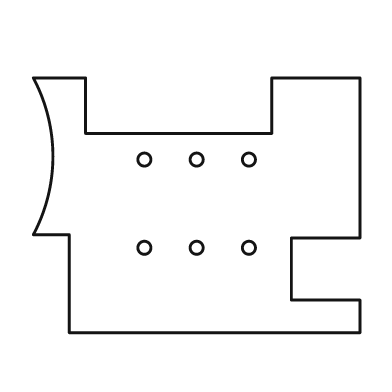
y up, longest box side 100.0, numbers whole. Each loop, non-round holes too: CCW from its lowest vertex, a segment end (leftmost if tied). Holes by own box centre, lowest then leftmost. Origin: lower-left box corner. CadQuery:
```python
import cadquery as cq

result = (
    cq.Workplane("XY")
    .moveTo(11.0, 0.0)
    .lineTo(100.0, 0.0)
    .lineTo(100.0, 10.0)
    .lineTo(79.0, 10.0)
    .lineTo(79.0, 29.0)
    .lineTo(100.0, 29.0)
    .lineTo(100.0, 78.0)
    .lineTo(73.0, 78.0)
    .lineTo(73.0, 61.0)
    .lineTo(16.0, 61.0)
    .lineTo(16.0, 78.0)
    .lineTo(0.0, 78.0)
    .threePointArc((6.0, 54.0), (0.0, 30.0))
    .lineTo(11.0, 30.0)
    .close()
    .moveTo(34.0, 26.0)
    .circle(2.0)
    .moveTo(50.0, 26.0)
    .circle(2.0)
    .moveTo(66.0, 26.0)
    .circle(2.0)
    .moveTo(34.0, 53.0)
    .circle(2.0)
    .moveTo(50.0, 53.0)
    .circle(2.0)
    .moveTo(66.0, 53.0)
    .circle(2.0)
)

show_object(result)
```